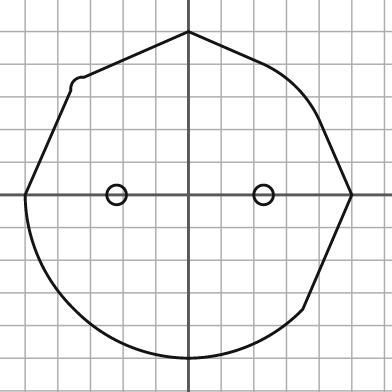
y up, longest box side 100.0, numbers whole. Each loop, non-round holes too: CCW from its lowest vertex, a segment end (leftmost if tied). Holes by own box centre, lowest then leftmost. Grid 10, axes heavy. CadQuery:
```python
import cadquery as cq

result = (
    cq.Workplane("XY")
    .moveTo(0.0, -50.0)
    .threePointArc((19.0, -46.0), (35.0, -35.0))
    .lineTo(50.0, 0.0)
    .lineTo(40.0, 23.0)
    .threePointArc((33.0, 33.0), (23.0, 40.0))
    .lineTo(0.0, 50.0)
    .lineTo(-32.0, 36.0)
    .threePointArc((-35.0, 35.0), (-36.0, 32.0))
    .lineTo(-50.0, 0.0)
    .threePointArc((-46.0, -19.0), (-35.0, -35.0))
    .threePointArc((-19.0, -46.0), (0.0, -50.0))
    .close()
    .moveTo(-22.0, 0.0)
    .circle(3.0)
    .moveTo(23.0, 0.0)
    .circle(3.0)
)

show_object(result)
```